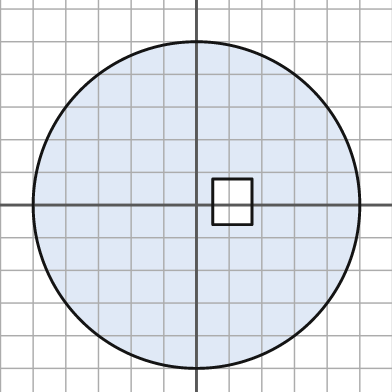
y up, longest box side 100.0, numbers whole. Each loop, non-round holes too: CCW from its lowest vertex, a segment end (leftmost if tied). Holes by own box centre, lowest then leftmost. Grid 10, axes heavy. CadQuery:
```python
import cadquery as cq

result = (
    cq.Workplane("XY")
    .moveTo(0.0, 0.0)
    .circle(50.0)
    .moveTo(5.0, -6.0)
    .lineTo(17.0, -6.0)
    .lineTo(17.0, 8.0)
    .lineTo(5.0, 8.0)
    .close()
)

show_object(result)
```